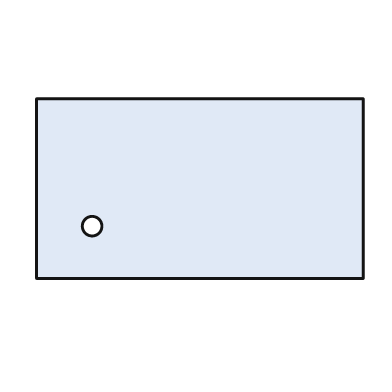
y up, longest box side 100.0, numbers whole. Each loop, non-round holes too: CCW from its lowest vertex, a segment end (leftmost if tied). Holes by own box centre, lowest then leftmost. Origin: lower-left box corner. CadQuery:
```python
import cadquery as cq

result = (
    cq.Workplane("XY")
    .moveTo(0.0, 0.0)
    .lineTo(100.0, 0.0)
    .lineTo(100.0, 55.0)
    .lineTo(0.0, 55.0)
    .close()
    .moveTo(17.0, 16.0)
    .circle(3.0)
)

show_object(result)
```